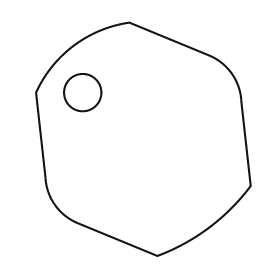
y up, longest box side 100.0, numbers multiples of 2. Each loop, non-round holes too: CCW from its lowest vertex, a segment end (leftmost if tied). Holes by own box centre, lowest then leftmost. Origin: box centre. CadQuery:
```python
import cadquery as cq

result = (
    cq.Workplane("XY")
    .moveTo(6.0, -50.0)
    .threePointArc((28.0, -38.0), (46.0, -20.0))
    .lineTo(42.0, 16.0)
    .threePointArc((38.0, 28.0), (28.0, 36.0))
    .lineTo(-6.0, 50.0)
    .threePointArc((-30.0, 40.0), (-46.0, 20.0))
    .lineTo(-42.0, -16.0)
    .threePointArc((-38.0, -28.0), (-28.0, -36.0))
    .close()
    .moveTo(-26.0, 20.0)
    .circle(8.0)
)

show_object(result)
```